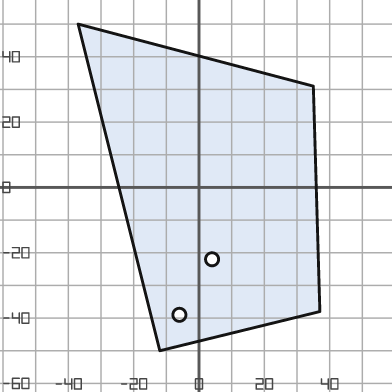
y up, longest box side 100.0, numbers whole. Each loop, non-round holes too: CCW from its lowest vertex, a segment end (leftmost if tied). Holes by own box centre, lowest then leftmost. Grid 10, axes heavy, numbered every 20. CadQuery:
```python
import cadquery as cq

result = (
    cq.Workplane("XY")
    .moveTo(-12.0, -50.0)
    .lineTo(37.0, -38.0)
    .lineTo(35.0, 31.0)
    .lineTo(-37.0, 50.0)
    .close()
    .moveTo(-6.0, -39.0)
    .circle(2.0)
    .moveTo(4.0, -22.0)
    .circle(2.0)
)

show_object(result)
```